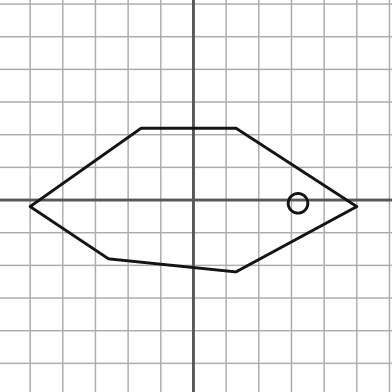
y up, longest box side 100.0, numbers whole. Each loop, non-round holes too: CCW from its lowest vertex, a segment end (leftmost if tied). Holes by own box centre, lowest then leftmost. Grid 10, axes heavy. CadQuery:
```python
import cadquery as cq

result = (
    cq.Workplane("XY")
    .moveTo(13.0, -22.0)
    .lineTo(50.0, -2.0)
    .lineTo(13.0, 22.0)
    .lineTo(-16.0, 22.0)
    .lineTo(-50.0, -2.0)
    .lineTo(-26.0, -18.0)
    .close()
    .moveTo(32.0, -1.0)
    .circle(3.0)
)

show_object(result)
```